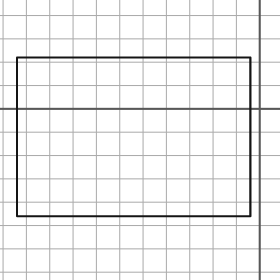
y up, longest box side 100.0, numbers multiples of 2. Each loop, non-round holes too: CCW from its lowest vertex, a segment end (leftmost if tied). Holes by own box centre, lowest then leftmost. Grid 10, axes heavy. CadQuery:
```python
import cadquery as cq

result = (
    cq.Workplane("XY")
    .moveTo(-104.0, -46.0)
    .lineTo(-4.0, -46.0)
    .lineTo(-4.0, 22.0)
    .lineTo(-104.0, 22.0)
    .close()
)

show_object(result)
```